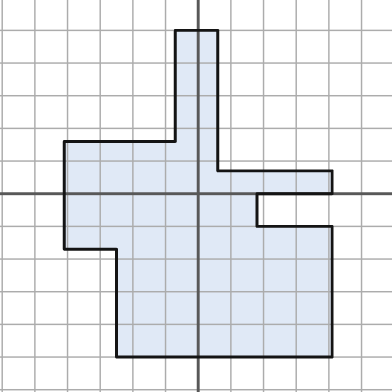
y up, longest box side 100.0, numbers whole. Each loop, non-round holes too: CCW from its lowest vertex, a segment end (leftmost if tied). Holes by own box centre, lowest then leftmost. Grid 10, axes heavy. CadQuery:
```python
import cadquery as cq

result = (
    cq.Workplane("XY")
    .moveTo(-25.0, -50.0)
    .lineTo(41.0, -50.0)
    .lineTo(41.0, -10.0)
    .lineTo(18.0, -10.0)
    .lineTo(18.0, 0.0)
    .lineTo(41.0, 0.0)
    .lineTo(41.0, 7.0)
    .lineTo(6.0, 7.0)
    .lineTo(6.0, 50.0)
    .lineTo(-7.0, 50.0)
    .lineTo(-7.0, 16.0)
    .lineTo(-41.0, 16.0)
    .lineTo(-41.0, -17.0)
    .lineTo(-25.0, -17.0)
    .close()
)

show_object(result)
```